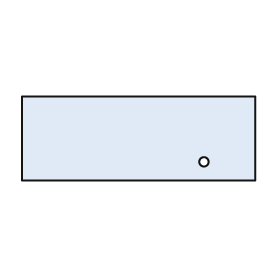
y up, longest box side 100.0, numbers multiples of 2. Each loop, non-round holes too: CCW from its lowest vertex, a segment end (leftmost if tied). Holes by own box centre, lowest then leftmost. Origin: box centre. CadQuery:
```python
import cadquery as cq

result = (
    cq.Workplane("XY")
    .moveTo(-50.0, -18.0)
    .lineTo(50.0, -18.0)
    .lineTo(50.0, 18.0)
    .lineTo(-50.0, 18.0)
    .close()
    .moveTo(28.0, -10.0)
    .circle(2.0)
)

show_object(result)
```